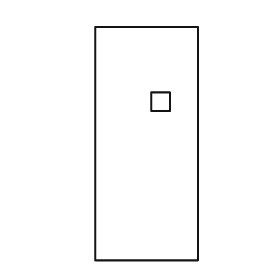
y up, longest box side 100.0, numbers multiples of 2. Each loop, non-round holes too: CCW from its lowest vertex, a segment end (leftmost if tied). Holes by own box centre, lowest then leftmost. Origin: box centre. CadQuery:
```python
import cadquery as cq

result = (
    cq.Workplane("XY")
    .moveTo(-22.0, -50.0)
    .lineTo(22.0, -50.0)
    .lineTo(22.0, 50.0)
    .lineTo(-22.0, 50.0)
    .close()
    .moveTo(2.0, 14.0)
    .lineTo(10.0, 14.0)
    .lineTo(10.0, 22.0)
    .lineTo(2.0, 22.0)
    .close()
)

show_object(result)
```